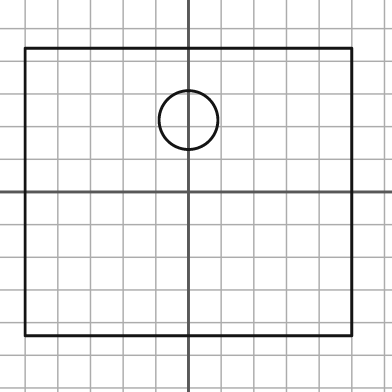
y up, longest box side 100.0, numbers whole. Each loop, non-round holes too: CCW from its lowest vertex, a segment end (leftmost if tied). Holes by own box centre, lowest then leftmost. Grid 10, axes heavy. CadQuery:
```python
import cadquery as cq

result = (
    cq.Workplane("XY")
    .moveTo(-50.0, -44.0)
    .lineTo(50.0, -44.0)
    .lineTo(50.0, 44.0)
    .lineTo(-50.0, 44.0)
    .close()
    .moveTo(0.0, 22.0)
    .circle(9.0)
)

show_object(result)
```